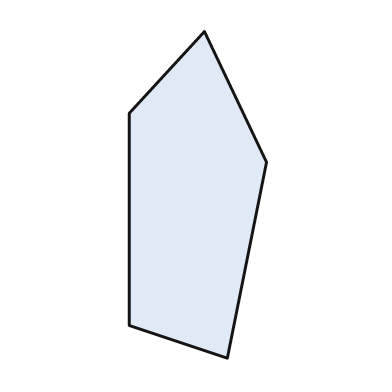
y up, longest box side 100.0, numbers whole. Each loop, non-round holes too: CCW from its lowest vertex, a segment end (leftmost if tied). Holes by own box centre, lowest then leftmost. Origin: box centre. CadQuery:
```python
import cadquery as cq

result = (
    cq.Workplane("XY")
    .moveTo(9.0, -50.0)
    .lineTo(21.0, 10.0)
    .lineTo(2.0, 50.0)
    .lineTo(-21.0, 25.0)
    .lineTo(-21.0, -40.0)
    .close()
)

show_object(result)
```